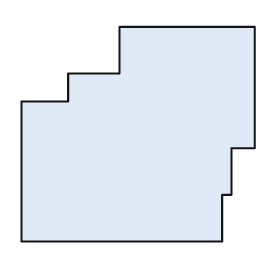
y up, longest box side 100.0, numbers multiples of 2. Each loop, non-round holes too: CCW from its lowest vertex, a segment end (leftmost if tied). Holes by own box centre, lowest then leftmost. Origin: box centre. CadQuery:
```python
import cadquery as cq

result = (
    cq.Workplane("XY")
    .moveTo(-50.0, -46.0)
    .lineTo(36.0, -46.0)
    .lineTo(36.0, -26.0)
    .lineTo(40.0, -26.0)
    .lineTo(40.0, -6.0)
    .lineTo(50.0, -6.0)
    .lineTo(50.0, 46.0)
    .lineTo(-8.0, 46.0)
    .lineTo(-8.0, 26.0)
    .lineTo(-30.0, 26.0)
    .lineTo(-30.0, 14.0)
    .lineTo(-50.0, 14.0)
    .close()
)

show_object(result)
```